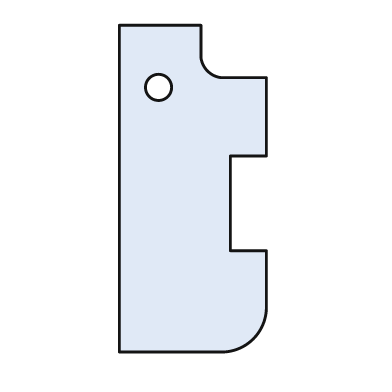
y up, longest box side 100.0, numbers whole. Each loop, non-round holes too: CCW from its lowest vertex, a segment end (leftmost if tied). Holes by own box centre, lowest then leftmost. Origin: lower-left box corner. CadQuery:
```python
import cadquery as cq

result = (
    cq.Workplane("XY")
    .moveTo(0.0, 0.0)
    .lineTo(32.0, 0.0)
    .threePointArc((41.0, 4.0), (45.0, 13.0))
    .lineTo(45.0, 31.0)
    .lineTo(34.0, 31.0)
    .lineTo(34.0, 60.0)
    .lineTo(45.0, 60.0)
    .lineTo(45.0, 84.0)
    .lineTo(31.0, 84.0)
    .threePointArc((27.0, 86.0), (25.0, 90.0))
    .lineTo(25.0, 100.0)
    .lineTo(0.0, 100.0)
    .close()
    .moveTo(12.0, 81.0)
    .circle(4.0)
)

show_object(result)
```